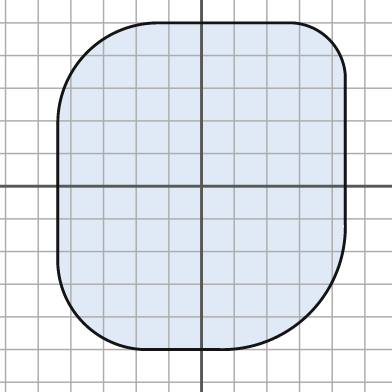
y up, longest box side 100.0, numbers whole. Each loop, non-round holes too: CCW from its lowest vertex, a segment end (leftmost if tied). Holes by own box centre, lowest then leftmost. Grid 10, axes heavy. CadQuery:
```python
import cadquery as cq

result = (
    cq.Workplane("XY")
    .moveTo(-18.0, -50.0)
    .lineTo(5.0, -50.0)
    .threePointArc((33.0, -39.0), (44.0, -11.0))
    .lineTo(44.0, 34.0)
    .threePointArc((39.0, 45.0), (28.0, 50.0))
    .lineTo(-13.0, 50.0)
    .threePointArc((-35.0, 41.0), (-44.0, 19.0))
    .lineTo(-44.0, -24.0)
    .threePointArc((-36.0, -42.0), (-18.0, -50.0))
    .close()
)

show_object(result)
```